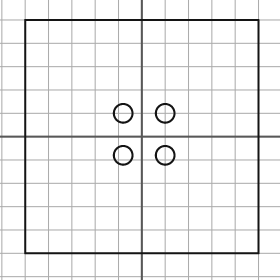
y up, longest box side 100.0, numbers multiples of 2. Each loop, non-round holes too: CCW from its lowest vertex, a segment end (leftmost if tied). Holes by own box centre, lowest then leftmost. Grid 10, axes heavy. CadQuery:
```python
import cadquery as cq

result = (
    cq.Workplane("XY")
    .moveTo(-50.0, -50.0)
    .lineTo(50.0, -50.0)
    .lineTo(50.0, 50.0)
    .lineTo(-50.0, 50.0)
    .close()
    .moveTo(-8.0, -8.0)
    .circle(4.0)
    .moveTo(10.0, -8.0)
    .circle(4.0)
    .moveTo(-8.0, 10.0)
    .circle(4.0)
    .moveTo(10.0, 10.0)
    .circle(4.0)
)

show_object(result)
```